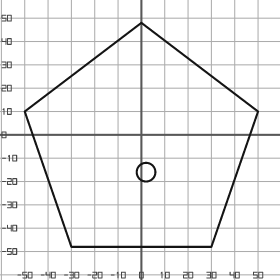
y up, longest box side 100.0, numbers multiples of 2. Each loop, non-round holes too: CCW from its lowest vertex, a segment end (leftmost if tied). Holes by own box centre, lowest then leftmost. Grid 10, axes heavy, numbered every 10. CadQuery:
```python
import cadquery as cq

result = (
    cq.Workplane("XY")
    .moveTo(-30.0, -48.0)
    .lineTo(30.0, -48.0)
    .lineTo(50.0, 10.0)
    .lineTo(0.0, 48.0)
    .lineTo(-50.0, 10.0)
    .close()
    .moveTo(2.0, -16.0)
    .circle(4.0)
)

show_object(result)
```